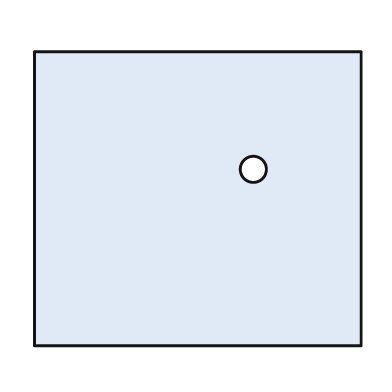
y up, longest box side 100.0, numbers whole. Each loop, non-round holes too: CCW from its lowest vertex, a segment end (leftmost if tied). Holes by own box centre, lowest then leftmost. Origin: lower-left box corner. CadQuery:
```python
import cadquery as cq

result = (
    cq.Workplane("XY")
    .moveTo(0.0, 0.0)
    .lineTo(100.0, 0.0)
    .lineTo(100.0, 90.0)
    .lineTo(0.0, 90.0)
    .close()
    .moveTo(67.0, 54.0)
    .circle(4.0)
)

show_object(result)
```